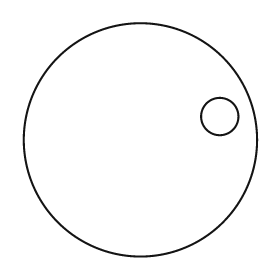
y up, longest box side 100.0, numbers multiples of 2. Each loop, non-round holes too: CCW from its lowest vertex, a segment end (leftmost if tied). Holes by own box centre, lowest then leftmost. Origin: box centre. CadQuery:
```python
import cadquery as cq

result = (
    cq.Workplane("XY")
    .moveTo(0.0, 0.0)
    .circle(50.0)
    .moveTo(34.0, 10.0)
    .circle(8.0)
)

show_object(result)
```